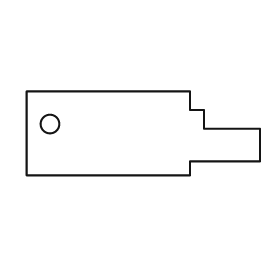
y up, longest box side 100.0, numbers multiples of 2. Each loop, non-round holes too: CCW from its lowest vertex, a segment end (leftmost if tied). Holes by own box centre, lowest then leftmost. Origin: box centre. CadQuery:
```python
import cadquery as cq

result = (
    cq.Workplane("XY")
    .moveTo(-50.0, -18.0)
    .lineTo(20.0, -18.0)
    .lineTo(20.0, -12.0)
    .lineTo(50.0, -12.0)
    .lineTo(50.0, 2.0)
    .lineTo(26.0, 2.0)
    .lineTo(26.0, 10.0)
    .lineTo(20.0, 10.0)
    .lineTo(20.0, 18.0)
    .lineTo(-50.0, 18.0)
    .close()
    .moveTo(-40.0, 4.0)
    .circle(4.0)
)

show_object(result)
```